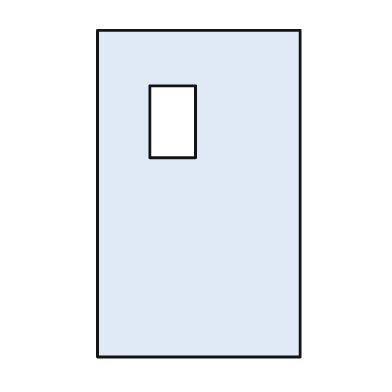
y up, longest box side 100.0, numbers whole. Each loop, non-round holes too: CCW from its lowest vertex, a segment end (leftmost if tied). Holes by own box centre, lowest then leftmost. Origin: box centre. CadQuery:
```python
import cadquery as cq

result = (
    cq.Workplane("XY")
    .moveTo(-31.0, -50.0)
    .lineTo(31.0, -50.0)
    .lineTo(31.0, 50.0)
    .lineTo(-31.0, 50.0)
    .close()
    .moveTo(-15.0, 11.0)
    .lineTo(-1.0, 11.0)
    .lineTo(-1.0, 33.0)
    .lineTo(-15.0, 33.0)
    .close()
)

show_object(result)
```